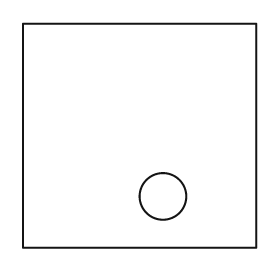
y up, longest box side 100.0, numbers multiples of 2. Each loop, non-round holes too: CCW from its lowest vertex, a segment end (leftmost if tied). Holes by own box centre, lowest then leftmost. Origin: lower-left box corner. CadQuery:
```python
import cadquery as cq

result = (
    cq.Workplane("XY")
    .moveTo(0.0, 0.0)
    .lineTo(100.0, 0.0)
    .lineTo(100.0, 96.0)
    .lineTo(0.0, 96.0)
    .close()
    .moveTo(60.0, 22.0)
    .circle(10.0)
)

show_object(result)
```